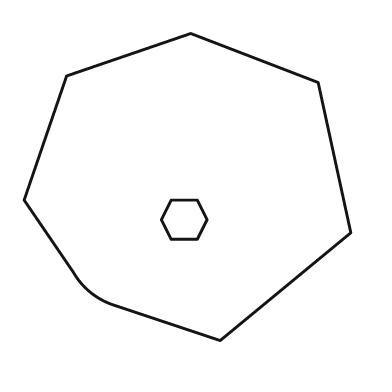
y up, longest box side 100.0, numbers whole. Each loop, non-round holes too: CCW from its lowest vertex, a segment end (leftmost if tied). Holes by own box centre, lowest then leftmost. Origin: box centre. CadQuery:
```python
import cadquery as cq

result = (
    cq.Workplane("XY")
    .moveTo(10.0, -47.0)
    .lineTo(50.0, -14.0)
    .lineTo(40.0, 32.0)
    .lineTo(1.0, 47.0)
    .lineTo(-37.0, 34.0)
    .lineTo(-50.0, -4.0)
    .lineTo(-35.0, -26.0)
    .threePointArc((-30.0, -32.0), (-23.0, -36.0))
    .close()
    .moveTo(-5.0, -16.0)
    .lineTo(3.0, -16.0)
    .lineTo(6.0, -10.0)
    .lineTo(3.0, -4.0)
    .lineTo(-5.0, -4.0)
    .lineTo(-8.0, -10.0)
    .close()
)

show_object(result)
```